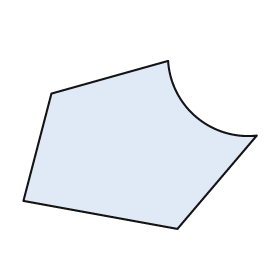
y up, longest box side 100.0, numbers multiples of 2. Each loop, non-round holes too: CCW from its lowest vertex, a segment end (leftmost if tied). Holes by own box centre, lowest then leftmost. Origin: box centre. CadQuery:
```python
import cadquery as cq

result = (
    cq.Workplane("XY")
    .moveTo(16.0, -36.0)
    .lineTo(50.0, 4.0)
    .threePointArc((24.0, 12.0), (12.0, 36.0))
    .lineTo(-38.0, 22.0)
    .lineTo(-50.0, -24.0)
    .close()
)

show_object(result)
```